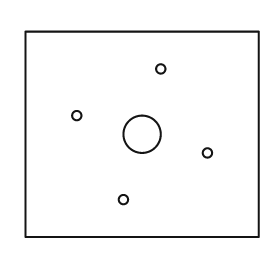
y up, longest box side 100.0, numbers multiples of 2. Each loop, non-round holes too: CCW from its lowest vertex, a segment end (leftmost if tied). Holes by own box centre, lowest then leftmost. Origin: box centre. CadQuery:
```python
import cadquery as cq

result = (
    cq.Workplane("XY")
    .moveTo(-50.0, -44.0)
    .lineTo(50.0, -44.0)
    .lineTo(50.0, 44.0)
    .lineTo(-50.0, 44.0)
    .close()
    .moveTo(-8.0, -28.0)
    .circle(2.0)
    .moveTo(28.0, -8.0)
    .circle(2.0)
    .moveTo(0.0, 0.0)
    .circle(8.0)
    .moveTo(-28.0, 8.0)
    .circle(2.0)
    .moveTo(8.0, 28.0)
    .circle(2.0)
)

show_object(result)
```